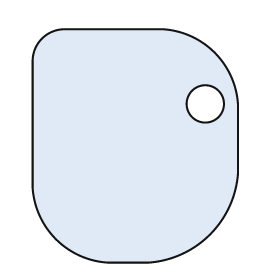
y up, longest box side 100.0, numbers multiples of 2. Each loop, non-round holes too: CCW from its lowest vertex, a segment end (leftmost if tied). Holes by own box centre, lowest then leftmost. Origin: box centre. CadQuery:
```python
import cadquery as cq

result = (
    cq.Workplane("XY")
    .moveTo(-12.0, -50.0)
    .lineTo(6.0, -50.0)
    .threePointArc((32.0, -38.0), (44.0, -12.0))
    .lineTo(44.0, 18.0)
    .threePointArc((34.0, 40.0), (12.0, 50.0))
    .lineTo(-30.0, 50.0)
    .threePointArc((-40.0, 46.0), (-44.0, 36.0))
    .lineTo(-44.0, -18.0)
    .threePointArc((-34.0, -40.0), (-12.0, -50.0))
    .close()
    .moveTo(30.0, 18.0)
    .circle(8.0)
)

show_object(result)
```